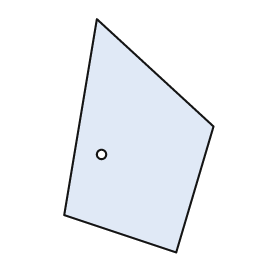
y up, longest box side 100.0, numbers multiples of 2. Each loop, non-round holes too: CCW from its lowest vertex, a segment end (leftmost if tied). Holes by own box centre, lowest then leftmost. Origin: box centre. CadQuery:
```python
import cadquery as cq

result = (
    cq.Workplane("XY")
    .moveTo(16.0, -50.0)
    .lineTo(32.0, 4.0)
    .lineTo(-18.0, 50.0)
    .lineTo(-32.0, -34.0)
    .close()
    .moveTo(-16.0, -8.0)
    .circle(2.0)
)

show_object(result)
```